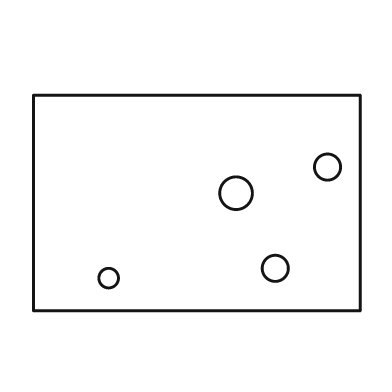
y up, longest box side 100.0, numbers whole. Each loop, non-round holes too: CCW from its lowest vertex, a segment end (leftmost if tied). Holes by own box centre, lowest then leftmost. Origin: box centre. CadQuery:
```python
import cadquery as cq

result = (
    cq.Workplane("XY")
    .moveTo(-50.0, -33.0)
    .lineTo(50.0, -33.0)
    .lineTo(50.0, 33.0)
    .lineTo(-50.0, 33.0)
    .close()
    .moveTo(-27.0, -23.0)
    .circle(3.0)
    .moveTo(24.0, -20.0)
    .circle(4.0)
    .moveTo(12.0, 3.0)
    .circle(5.0)
    .moveTo(40.0, 11.0)
    .circle(4.0)
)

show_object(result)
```